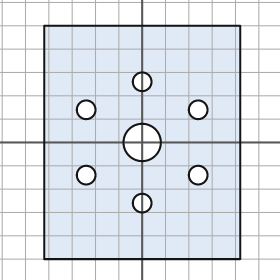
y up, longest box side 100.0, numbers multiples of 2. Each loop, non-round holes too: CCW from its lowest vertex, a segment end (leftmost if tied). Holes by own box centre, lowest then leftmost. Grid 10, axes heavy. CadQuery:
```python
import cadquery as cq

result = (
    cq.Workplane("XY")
    .moveTo(-42.0, -50.0)
    .lineTo(42.0, -50.0)
    .lineTo(42.0, 50.0)
    .lineTo(-42.0, 50.0)
    .close()
    .moveTo(0.0, -26.0)
    .circle(4.0)
    .moveTo(-24.0, -14.0)
    .circle(4.0)
    .moveTo(24.0, -14.0)
    .circle(4.0)
    .moveTo(0.0, 0.0)
    .circle(8.0)
    .moveTo(-24.0, 14.0)
    .circle(4.0)
    .moveTo(24.0, 14.0)
    .circle(4.0)
    .moveTo(0.0, 26.0)
    .circle(4.0)
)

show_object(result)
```